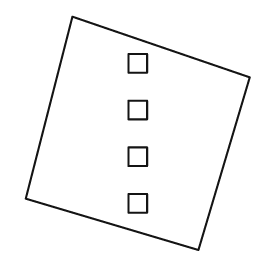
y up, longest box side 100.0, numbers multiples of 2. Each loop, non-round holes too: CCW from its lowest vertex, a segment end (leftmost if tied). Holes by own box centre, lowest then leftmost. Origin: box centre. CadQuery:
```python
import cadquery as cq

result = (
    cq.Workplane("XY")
    .moveTo(26.0, -50.0)
    .lineTo(48.0, 24.0)
    .lineTo(-28.0, 50.0)
    .lineTo(-48.0, -28.0)
    .close()
    .moveTo(-4.0, -34.0)
    .lineTo(4.0, -34.0)
    .lineTo(4.0, -26.0)
    .lineTo(-4.0, -26.0)
    .close()
    .moveTo(-4.0, -14.0)
    .lineTo(4.0, -14.0)
    .lineTo(4.0, -6.0)
    .lineTo(-4.0, -6.0)
    .close()
    .moveTo(-4.0, 6.0)
    .lineTo(4.0, 6.0)
    .lineTo(4.0, 14.0)
    .lineTo(-4.0, 14.0)
    .close()
    .moveTo(-4.0, 26.0)
    .lineTo(4.0, 26.0)
    .lineTo(4.0, 34.0)
    .lineTo(-4.0, 34.0)
    .close()
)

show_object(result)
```